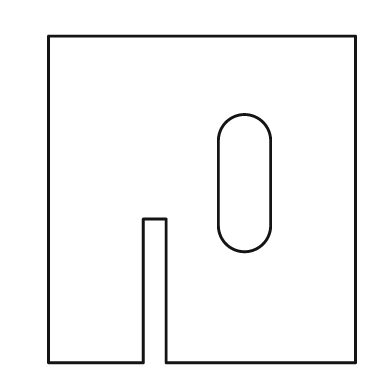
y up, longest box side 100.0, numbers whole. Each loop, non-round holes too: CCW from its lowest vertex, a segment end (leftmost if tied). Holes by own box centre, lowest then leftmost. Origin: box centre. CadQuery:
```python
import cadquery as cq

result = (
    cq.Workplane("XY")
    .moveTo(-47.0, -50.0)
    .lineTo(-18.0, -50.0)
    .lineTo(-18.0, -6.0)
    .lineTo(-11.0, -6.0)
    .lineTo(-11.0, -50.0)
    .lineTo(47.0, -50.0)
    .lineTo(47.0, 50.0)
    .lineTo(-47.0, 50.0)
    .close()
    .moveTo(5.0, -8.0)
    .threePointArc((13.0, -16.0), (21.0, -8.0))
    .lineTo(21.0, 18.0)
    .threePointArc((13.0, 26.0), (5.0, 18.0))
    .close()
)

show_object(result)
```